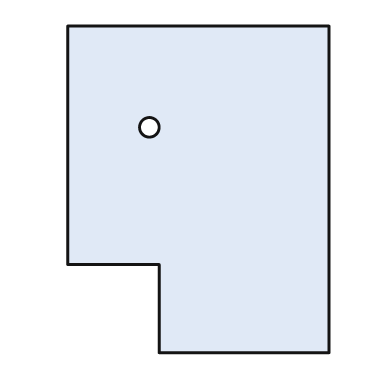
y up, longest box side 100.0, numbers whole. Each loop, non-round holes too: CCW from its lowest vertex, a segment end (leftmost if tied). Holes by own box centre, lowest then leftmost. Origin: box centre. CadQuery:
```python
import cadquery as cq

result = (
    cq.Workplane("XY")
    .moveTo(-12.0, -50.0)
    .lineTo(40.0, -50.0)
    .lineTo(40.0, 50.0)
    .lineTo(-40.0, 50.0)
    .lineTo(-40.0, -23.0)
    .lineTo(-12.0, -23.0)
    .close()
    .moveTo(-15.0, 19.0)
    .circle(3.0)
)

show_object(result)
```